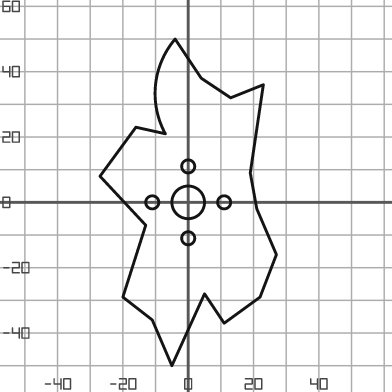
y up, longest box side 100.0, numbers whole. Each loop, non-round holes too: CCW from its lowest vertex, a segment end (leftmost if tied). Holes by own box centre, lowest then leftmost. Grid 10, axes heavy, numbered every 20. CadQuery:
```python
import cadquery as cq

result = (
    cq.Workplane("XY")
    .moveTo(-5.0, -50.0)
    .lineTo(5.0, -28.0)
    .lineTo(11.0, -37.0)
    .lineTo(22.0, -29.0)
    .lineTo(27.0, -16.0)
    .lineTo(21.0, -2.0)
    .lineTo(19.0, 9.0)
    .lineTo(23.0, 36.0)
    .lineTo(13.0, 32.0)
    .lineTo(4.0, 38.0)
    .lineTo(-4.0, 50.0)
    .threePointArc((-10.0, 36.0), (-7.0, 21.0))
    .lineTo(-16.0, 23.0)
    .lineTo(-27.0, 8.0)
    .lineTo(-13.0, -7.0)
    .lineTo(-20.0, -29.0)
    .lineTo(-11.0, -36.0)
    .close()
    .moveTo(0.0, -11.0)
    .circle(2.0)
    .moveTo(-11.0, 0.0)
    .circle(2.0)
    .moveTo(0.0, 0.0)
    .circle(5.0)
    .moveTo(11.0, 0.0)
    .circle(2.0)
    .moveTo(0.0, 11.0)
    .circle(2.0)
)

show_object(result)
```